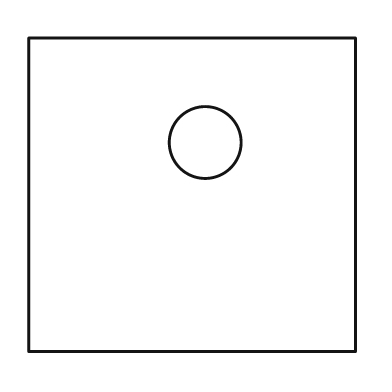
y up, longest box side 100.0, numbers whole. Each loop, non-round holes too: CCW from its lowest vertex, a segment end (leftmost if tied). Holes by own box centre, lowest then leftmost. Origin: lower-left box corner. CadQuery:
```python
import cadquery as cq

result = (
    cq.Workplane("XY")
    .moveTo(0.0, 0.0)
    .lineTo(100.0, 0.0)
    .lineTo(100.0, 96.0)
    .lineTo(0.0, 96.0)
    .close()
    .moveTo(54.0, 64.0)
    .circle(11.0)
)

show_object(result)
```